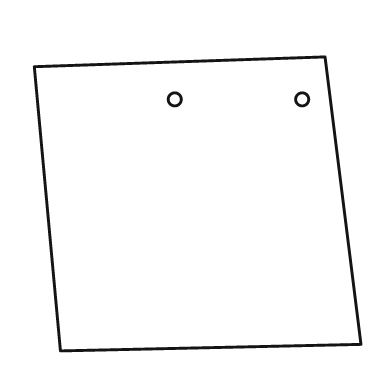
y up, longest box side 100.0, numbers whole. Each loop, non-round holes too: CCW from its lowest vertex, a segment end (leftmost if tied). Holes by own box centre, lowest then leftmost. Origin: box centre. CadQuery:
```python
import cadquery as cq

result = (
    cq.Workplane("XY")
    .moveTo(-42.0, -45.0)
    .lineTo(50.0, -43.0)
    .lineTo(39.0, 45.0)
    .lineTo(-50.0, 42.0)
    .close()
    .moveTo(-7.0, 32.0)
    .circle(2.0)
    .moveTo(32.0, 32.0)
    .circle(2.0)
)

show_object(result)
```